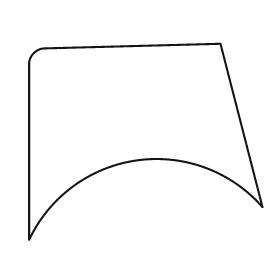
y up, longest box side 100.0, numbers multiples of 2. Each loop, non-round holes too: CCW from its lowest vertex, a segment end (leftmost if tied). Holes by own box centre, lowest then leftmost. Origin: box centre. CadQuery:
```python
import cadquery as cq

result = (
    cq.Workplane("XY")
    .moveTo(-50.0, -42.0)
    .threePointArc((-4.0, -8.0), (50.0, -28.0))
    .lineTo(32.0, 42.0)
    .lineTo(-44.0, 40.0)
    .threePointArc((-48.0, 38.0), (-50.0, 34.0))
    .close()
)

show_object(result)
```